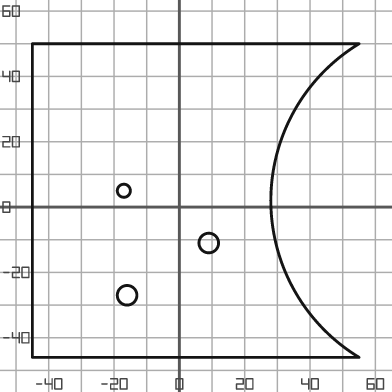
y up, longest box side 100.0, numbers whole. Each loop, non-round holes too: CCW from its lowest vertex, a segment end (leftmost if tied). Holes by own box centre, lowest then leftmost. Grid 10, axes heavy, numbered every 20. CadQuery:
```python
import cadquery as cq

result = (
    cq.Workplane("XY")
    .moveTo(-45.0, -46.0)
    .lineTo(55.0, -46.0)
    .threePointArc((28.0, 2.0), (55.0, 50.0))
    .lineTo(-45.0, 50.0)
    .close()
    .moveTo(-16.0, -27.0)
    .circle(3.0)
    .moveTo(9.0, -11.0)
    .circle(3.0)
    .moveTo(-17.0, 5.0)
    .circle(2.0)
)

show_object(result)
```